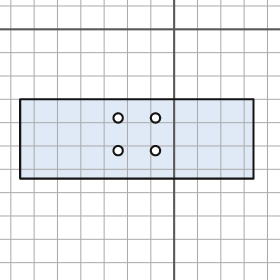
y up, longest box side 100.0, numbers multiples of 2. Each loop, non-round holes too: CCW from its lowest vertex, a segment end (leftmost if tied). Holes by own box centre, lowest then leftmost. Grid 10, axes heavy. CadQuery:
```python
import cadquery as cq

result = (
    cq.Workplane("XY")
    .moveTo(-66.0, -64.0)
    .lineTo(34.0, -64.0)
    .lineTo(34.0, -30.0)
    .lineTo(-66.0, -30.0)
    .close()
    .moveTo(-24.0, -52.0)
    .circle(2.0)
    .moveTo(-8.0, -52.0)
    .circle(2.0)
    .moveTo(-24.0, -38.0)
    .circle(2.0)
    .moveTo(-8.0, -38.0)
    .circle(2.0)
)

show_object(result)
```